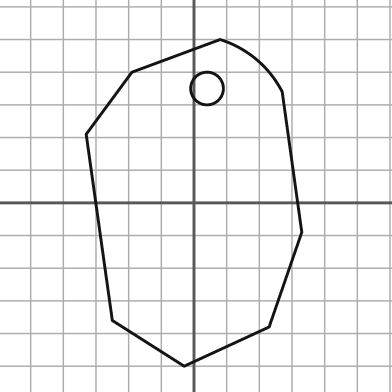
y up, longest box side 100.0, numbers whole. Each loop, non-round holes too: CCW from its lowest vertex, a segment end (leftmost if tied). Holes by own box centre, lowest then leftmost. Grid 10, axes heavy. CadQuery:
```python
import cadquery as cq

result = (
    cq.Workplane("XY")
    .moveTo(-3.0, -50.0)
    .lineTo(23.0, -38.0)
    .lineTo(33.0, -9.0)
    .lineTo(27.0, 34.0)
    .threePointArc((19.0, 44.0), (8.0, 50.0))
    .lineTo(-19.0, 40.0)
    .lineTo(-33.0, 21.0)
    .lineTo(-25.0, -36.0)
    .close()
    .moveTo(4.0, 35.0)
    .circle(5.0)
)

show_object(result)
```